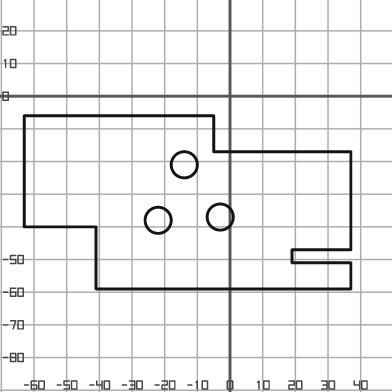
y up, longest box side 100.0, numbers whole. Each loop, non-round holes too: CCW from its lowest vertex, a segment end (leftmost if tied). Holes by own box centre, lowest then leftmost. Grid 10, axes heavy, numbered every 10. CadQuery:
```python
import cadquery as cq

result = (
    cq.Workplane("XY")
    .moveTo(-41.0, -59.0)
    .lineTo(37.0, -59.0)
    .lineTo(37.0, -51.0)
    .lineTo(19.0, -51.0)
    .lineTo(19.0, -47.0)
    .lineTo(37.0, -47.0)
    .lineTo(37.0, -17.0)
    .lineTo(-5.0, -17.0)
    .lineTo(-5.0, -6.0)
    .lineTo(-63.0, -6.0)
    .lineTo(-63.0, -40.0)
    .lineTo(-41.0, -40.0)
    .close()
    .moveTo(-22.0, -38.0)
    .circle(4.0)
    .moveTo(-3.0, -37.0)
    .circle(4.0)
    .moveTo(-14.0, -21.0)
    .circle(4.0)
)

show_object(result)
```